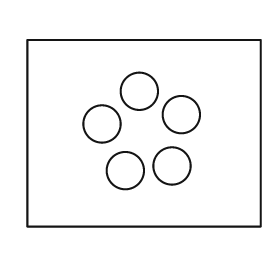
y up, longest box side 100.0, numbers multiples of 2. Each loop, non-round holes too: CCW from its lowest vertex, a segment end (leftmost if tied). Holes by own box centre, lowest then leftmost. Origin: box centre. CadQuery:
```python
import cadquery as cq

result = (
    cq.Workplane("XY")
    .moveTo(-50.0, -40.0)
    .lineTo(50.0, -40.0)
    .lineTo(50.0, 40.0)
    .lineTo(-50.0, 40.0)
    .close()
    .moveTo(-8.0, -16.0)
    .circle(8.0)
    .moveTo(12.0, -14.0)
    .circle(8.0)
    .moveTo(-18.0, 4.0)
    .circle(8.0)
    .moveTo(16.0, 8.0)
    .circle(8.0)
    .moveTo(-2.0, 18.0)
    .circle(8.0)
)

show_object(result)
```